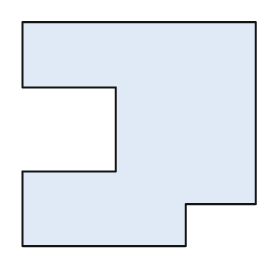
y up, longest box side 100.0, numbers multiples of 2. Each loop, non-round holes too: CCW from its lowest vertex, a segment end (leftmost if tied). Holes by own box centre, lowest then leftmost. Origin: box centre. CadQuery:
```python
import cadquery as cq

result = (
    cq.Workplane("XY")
    .moveTo(-50.0, -48.0)
    .lineTo(20.0, -48.0)
    .lineTo(20.0, -30.0)
    .lineTo(50.0, -30.0)
    .lineTo(50.0, 48.0)
    .lineTo(-50.0, 48.0)
    .lineTo(-50.0, 20.0)
    .lineTo(-10.0, 20.0)
    .lineTo(-10.0, -16.0)
    .lineTo(-50.0, -16.0)
    .close()
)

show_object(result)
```